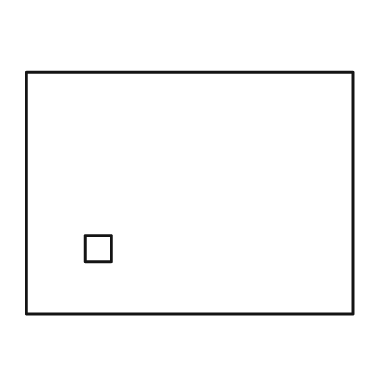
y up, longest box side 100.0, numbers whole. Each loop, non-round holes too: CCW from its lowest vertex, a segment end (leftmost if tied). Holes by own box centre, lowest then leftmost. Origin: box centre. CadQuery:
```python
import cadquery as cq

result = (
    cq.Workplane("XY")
    .moveTo(-50.0, -37.0)
    .lineTo(50.0, -37.0)
    .lineTo(50.0, 37.0)
    .lineTo(-50.0, 37.0)
    .close()
    .moveTo(-32.0, -21.0)
    .lineTo(-24.0, -21.0)
    .lineTo(-24.0, -13.0)
    .lineTo(-32.0, -13.0)
    .close()
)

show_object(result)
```